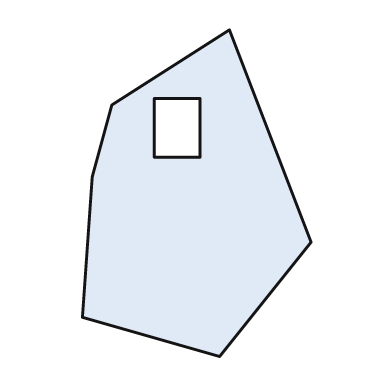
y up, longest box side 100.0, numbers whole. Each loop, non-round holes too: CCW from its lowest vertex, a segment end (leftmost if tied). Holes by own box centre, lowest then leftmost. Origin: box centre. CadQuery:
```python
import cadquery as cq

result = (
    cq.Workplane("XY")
    .moveTo(7.0, -50.0)
    .lineTo(35.0, -15.0)
    .lineTo(10.0, 50.0)
    .lineTo(-26.0, 27.0)
    .lineTo(-32.0, 5.0)
    .lineTo(-35.0, -38.0)
    .close()
    .moveTo(-13.0, 11.0)
    .lineTo(1.0, 11.0)
    .lineTo(1.0, 29.0)
    .lineTo(-13.0, 29.0)
    .close()
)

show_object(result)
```